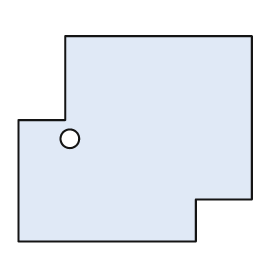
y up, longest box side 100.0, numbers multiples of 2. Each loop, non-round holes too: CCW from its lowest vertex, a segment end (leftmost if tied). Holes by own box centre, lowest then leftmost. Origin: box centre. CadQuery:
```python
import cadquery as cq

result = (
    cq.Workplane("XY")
    .moveTo(-50.0, -44.0)
    .lineTo(26.0, -44.0)
    .lineTo(26.0, -26.0)
    .lineTo(50.0, -26.0)
    .lineTo(50.0, 44.0)
    .lineTo(-30.0, 44.0)
    .lineTo(-30.0, 8.0)
    .lineTo(-50.0, 8.0)
    .close()
    .moveTo(-28.0, 0.0)
    .circle(4.0)
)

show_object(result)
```